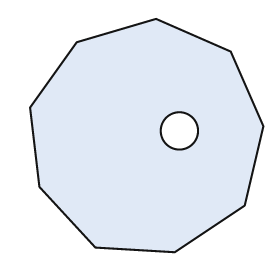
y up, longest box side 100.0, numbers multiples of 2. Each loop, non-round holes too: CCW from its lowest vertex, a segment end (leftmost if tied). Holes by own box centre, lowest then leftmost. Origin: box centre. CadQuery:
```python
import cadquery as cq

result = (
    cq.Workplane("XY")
    .moveTo(12.0, -50.0)
    .lineTo(42.0, -30.0)
    .lineTo(50.0, 4.0)
    .lineTo(36.0, 36.0)
    .lineTo(4.0, 50.0)
    .lineTo(-30.0, 40.0)
    .lineTo(-50.0, 12.0)
    .lineTo(-46.0, -22.0)
    .lineTo(-22.0, -48.0)
    .close()
    .moveTo(14.0, 2.0)
    .circle(8.0)
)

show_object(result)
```